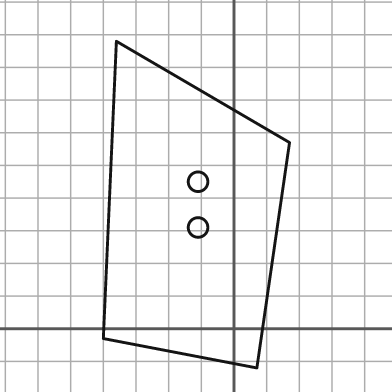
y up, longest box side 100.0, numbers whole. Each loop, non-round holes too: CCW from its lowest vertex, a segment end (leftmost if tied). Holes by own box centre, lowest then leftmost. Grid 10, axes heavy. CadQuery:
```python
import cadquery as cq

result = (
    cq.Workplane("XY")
    .moveTo(7.0, -12.0)
    .lineTo(17.0, 57.0)
    .lineTo(-36.0, 88.0)
    .lineTo(-40.0, -3.0)
    .close()
    .moveTo(-11.0, 31.0)
    .circle(3.0)
    .moveTo(-11.0, 45.0)
    .circle(3.0)
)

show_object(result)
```